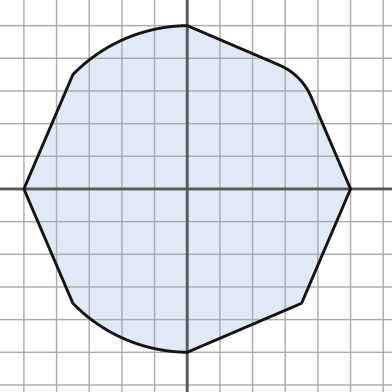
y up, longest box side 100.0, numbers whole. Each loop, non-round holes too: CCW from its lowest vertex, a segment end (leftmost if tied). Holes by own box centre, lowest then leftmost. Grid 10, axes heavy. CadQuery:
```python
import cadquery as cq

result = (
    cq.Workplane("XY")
    .moveTo(0.0, -50.0)
    .lineTo(35.0, -35.0)
    .lineTo(50.0, 0.0)
    .lineTo(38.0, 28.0)
    .threePointArc((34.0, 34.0), (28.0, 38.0))
    .lineTo(0.0, 50.0)
    .threePointArc((-19.0, 46.0), (-35.0, 35.0))
    .lineTo(-50.0, 0.0)
    .lineTo(-35.0, -35.0)
    .threePointArc((-19.0, -46.0), (0.0, -50.0))
    .close()
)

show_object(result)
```